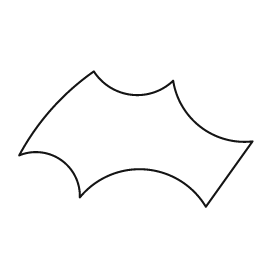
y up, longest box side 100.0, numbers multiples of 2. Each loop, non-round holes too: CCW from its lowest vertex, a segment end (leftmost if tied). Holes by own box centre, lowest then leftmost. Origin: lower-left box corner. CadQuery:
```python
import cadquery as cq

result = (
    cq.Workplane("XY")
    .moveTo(80.0, 0.0)
    .lineTo(100.0, 28.0)
    .threePointArc((78.0, 34.0), (66.0, 54.0))
    .threePointArc((48.0, 48.0), (32.0, 58.0))
    .threePointArc((14.0, 42.0), (0.0, 22.0))
    .threePointArc((18.0, 20.0), (26.0, 4.0))
    .threePointArc((54.0, 16.0), (80.0, 0.0))
    .close()
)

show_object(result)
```